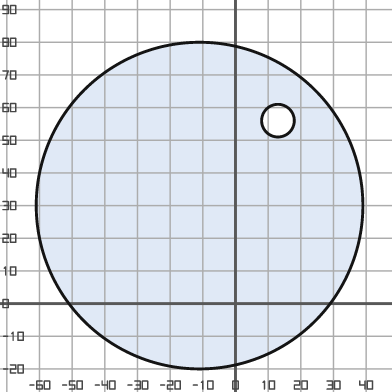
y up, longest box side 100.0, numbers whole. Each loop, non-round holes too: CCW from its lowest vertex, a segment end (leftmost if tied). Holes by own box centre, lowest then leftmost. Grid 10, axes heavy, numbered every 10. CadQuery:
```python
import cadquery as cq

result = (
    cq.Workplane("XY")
    .moveTo(-11.0, 30.0)
    .circle(50.0)
    .moveTo(13.0, 56.0)
    .circle(5.0)
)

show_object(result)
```